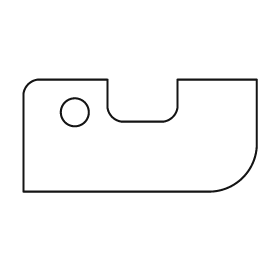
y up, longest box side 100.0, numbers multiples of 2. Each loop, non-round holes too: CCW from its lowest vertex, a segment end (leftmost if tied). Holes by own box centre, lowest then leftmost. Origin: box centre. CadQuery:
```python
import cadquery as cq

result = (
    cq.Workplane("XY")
    .moveTo(-50.0, -24.0)
    .lineTo(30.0, -24.0)
    .threePointArc((44.0, -18.0), (50.0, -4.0))
    .lineTo(50.0, 24.0)
    .lineTo(16.0, 24.0)
    .lineTo(16.0, 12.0)
    .threePointArc((14.0, 8.0), (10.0, 6.0))
    .lineTo(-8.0, 6.0)
    .threePointArc((-12.0, 8.0), (-14.0, 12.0))
    .lineTo(-14.0, 24.0)
    .lineTo(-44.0, 24.0)
    .threePointArc((-48.0, 22.0), (-50.0, 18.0))
    .close()
    .moveTo(-28.0, 10.0)
    .circle(6.0)
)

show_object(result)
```